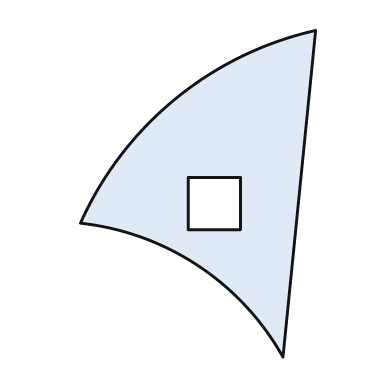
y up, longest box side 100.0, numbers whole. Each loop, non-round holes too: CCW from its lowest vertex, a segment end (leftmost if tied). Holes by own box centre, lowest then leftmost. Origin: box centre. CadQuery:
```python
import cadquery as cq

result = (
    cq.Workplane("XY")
    .moveTo(26.0, -50.0)
    .lineTo(36.0, 50.0)
    .threePointArc((-7.0, 29.0), (-36.0, -9.0))
    .threePointArc((0.0, -22.0), (26.0, -50.0))
    .close()
    .moveTo(-3.0, -11.0)
    .lineTo(13.0, -11.0)
    .lineTo(13.0, 5.0)
    .lineTo(-3.0, 5.0)
    .close()
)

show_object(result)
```